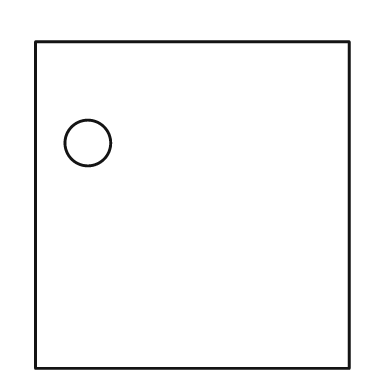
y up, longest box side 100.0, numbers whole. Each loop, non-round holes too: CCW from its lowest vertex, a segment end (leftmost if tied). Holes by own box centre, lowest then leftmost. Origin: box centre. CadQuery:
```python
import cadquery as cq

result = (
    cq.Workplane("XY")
    .moveTo(-48.0, -50.0)
    .lineTo(48.0, -50.0)
    .lineTo(48.0, 50.0)
    .lineTo(-48.0, 50.0)
    .close()
    .moveTo(-32.0, 19.0)
    .circle(7.0)
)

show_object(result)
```